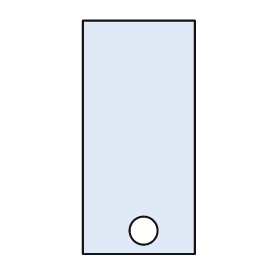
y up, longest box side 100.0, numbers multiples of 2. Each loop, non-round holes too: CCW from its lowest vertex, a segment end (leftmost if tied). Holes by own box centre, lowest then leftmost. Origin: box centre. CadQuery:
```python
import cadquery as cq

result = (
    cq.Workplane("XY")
    .moveTo(-24.0, -50.0)
    .lineTo(24.0, -50.0)
    .lineTo(24.0, 50.0)
    .lineTo(-24.0, 50.0)
    .close()
    .moveTo(2.0, -40.0)
    .circle(6.0)
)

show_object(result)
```